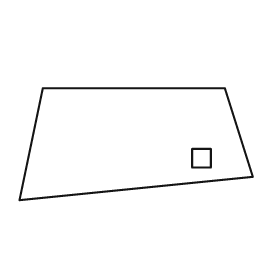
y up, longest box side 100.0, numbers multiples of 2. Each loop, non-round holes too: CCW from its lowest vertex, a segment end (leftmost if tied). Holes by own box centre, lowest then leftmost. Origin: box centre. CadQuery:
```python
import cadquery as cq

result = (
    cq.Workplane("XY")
    .moveTo(-50.0, -24.0)
    .lineTo(50.0, -14.0)
    .lineTo(38.0, 24.0)
    .lineTo(-40.0, 24.0)
    .close()
    .moveTo(24.0, -10.0)
    .lineTo(32.0, -10.0)
    .lineTo(32.0, -2.0)
    .lineTo(24.0, -2.0)
    .close()
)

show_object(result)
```